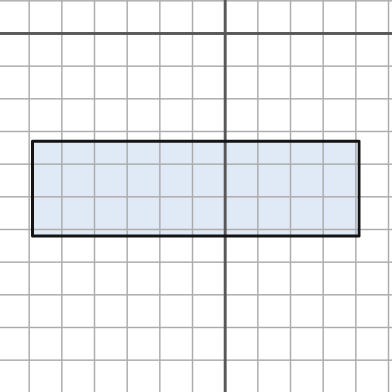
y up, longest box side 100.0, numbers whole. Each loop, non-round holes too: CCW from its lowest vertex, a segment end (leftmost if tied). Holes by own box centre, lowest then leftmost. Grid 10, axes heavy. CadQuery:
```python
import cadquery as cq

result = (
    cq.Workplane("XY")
    .moveTo(-59.0, -62.0)
    .lineTo(41.0, -62.0)
    .lineTo(41.0, -33.0)
    .lineTo(-59.0, -33.0)
    .close()
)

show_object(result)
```